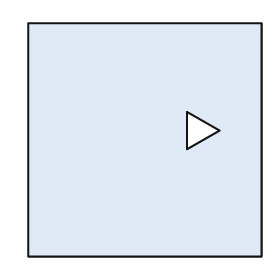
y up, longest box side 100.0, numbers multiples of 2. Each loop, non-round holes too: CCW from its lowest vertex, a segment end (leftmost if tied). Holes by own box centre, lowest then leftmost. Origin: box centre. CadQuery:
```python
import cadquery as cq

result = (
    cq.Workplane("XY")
    .moveTo(-50.0, -50.0)
    .lineTo(50.0, -50.0)
    .lineTo(50.0, 50.0)
    .lineTo(-50.0, 50.0)
    .close()
    .moveTo(18.0, -4.0)
    .lineTo(32.0, 4.0)
    .lineTo(18.0, 12.0)
    .close()
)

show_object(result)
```